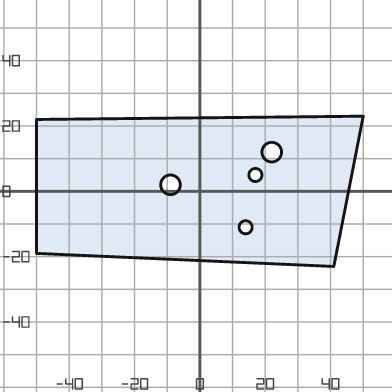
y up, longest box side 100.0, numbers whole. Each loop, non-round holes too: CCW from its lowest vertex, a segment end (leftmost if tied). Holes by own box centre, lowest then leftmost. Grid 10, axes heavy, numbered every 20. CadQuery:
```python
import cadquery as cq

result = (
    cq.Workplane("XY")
    .moveTo(41.0, -23.0)
    .lineTo(50.0, 23.0)
    .lineTo(-50.0, 22.0)
    .lineTo(-50.0, -19.0)
    .close()
    .moveTo(14.0, -11.0)
    .circle(2.0)
    .moveTo(-9.0, 2.0)
    .circle(3.0)
    .moveTo(17.0, 5.0)
    .circle(2.0)
    .moveTo(22.0, 12.0)
    .circle(3.0)
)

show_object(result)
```